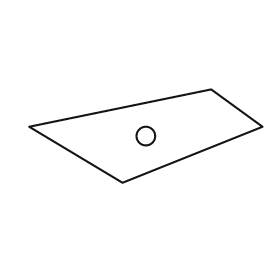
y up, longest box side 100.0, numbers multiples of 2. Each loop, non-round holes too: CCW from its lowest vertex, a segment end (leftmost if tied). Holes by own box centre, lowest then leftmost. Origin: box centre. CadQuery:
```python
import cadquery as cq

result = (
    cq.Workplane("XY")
    .moveTo(-10.0, -20.0)
    .lineTo(50.0, 4.0)
    .lineTo(28.0, 20.0)
    .lineTo(-50.0, 4.0)
    .close()
    .moveTo(0.0, 0.0)
    .circle(4.0)
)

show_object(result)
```